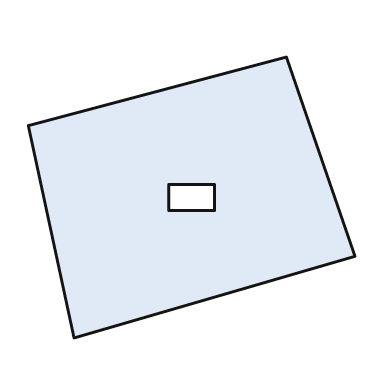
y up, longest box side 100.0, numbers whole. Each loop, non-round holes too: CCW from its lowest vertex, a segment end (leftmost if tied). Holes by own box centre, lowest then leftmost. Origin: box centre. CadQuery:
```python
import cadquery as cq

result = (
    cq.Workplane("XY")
    .moveTo(-36.0, -43.0)
    .lineTo(50.0, -18.0)
    .lineTo(29.0, 43.0)
    .lineTo(-50.0, 22.0)
    .close()
    .moveTo(-7.0, -4.0)
    .lineTo(7.0, -4.0)
    .lineTo(7.0, 4.0)
    .lineTo(-7.0, 4.0)
    .close()
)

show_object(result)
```